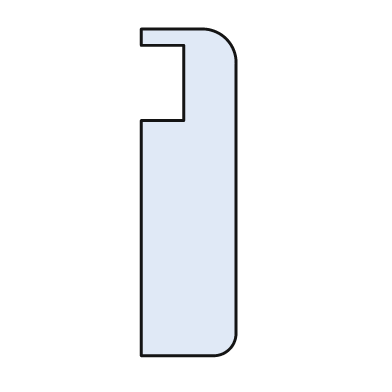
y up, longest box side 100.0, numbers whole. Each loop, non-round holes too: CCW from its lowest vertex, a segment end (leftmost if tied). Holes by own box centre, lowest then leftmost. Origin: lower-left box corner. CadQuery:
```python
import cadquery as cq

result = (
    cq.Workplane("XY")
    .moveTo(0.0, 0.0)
    .lineTo(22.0, 0.0)
    .threePointArc((27.0, 2.0), (29.0, 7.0))
    .lineTo(29.0, 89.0)
    .threePointArc((26.0, 97.0), (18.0, 100.0))
    .lineTo(0.0, 100.0)
    .lineTo(0.0, 95.0)
    .lineTo(13.0, 95.0)
    .lineTo(13.0, 72.0)
    .lineTo(0.0, 72.0)
    .close()
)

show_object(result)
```